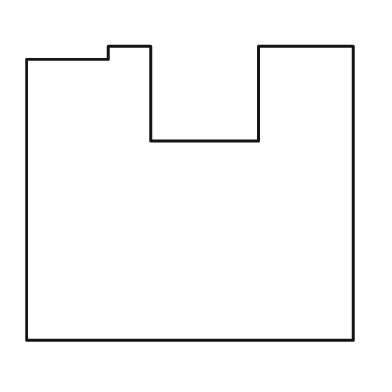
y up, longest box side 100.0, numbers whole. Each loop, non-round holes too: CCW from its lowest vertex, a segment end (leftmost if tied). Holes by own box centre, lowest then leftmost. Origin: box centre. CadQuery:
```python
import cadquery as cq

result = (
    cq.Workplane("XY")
    .moveTo(-50.0, -45.0)
    .lineTo(50.0, -45.0)
    .lineTo(50.0, 45.0)
    .lineTo(21.0, 45.0)
    .lineTo(21.0, 16.0)
    .lineTo(-12.0, 16.0)
    .lineTo(-12.0, 45.0)
    .lineTo(-25.0, 45.0)
    .lineTo(-25.0, 41.0)
    .lineTo(-50.0, 41.0)
    .close()
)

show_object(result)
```